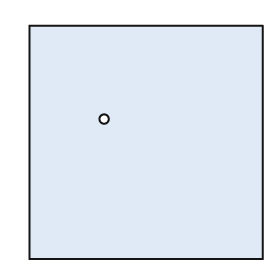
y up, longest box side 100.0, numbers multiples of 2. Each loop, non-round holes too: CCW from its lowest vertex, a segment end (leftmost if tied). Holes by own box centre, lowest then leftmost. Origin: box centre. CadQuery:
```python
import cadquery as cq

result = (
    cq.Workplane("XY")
    .moveTo(-50.0, -50.0)
    .lineTo(50.0, -50.0)
    .lineTo(50.0, 50.0)
    .lineTo(-50.0, 50.0)
    .close()
    .moveTo(-18.0, 10.0)
    .circle(2.0)
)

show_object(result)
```